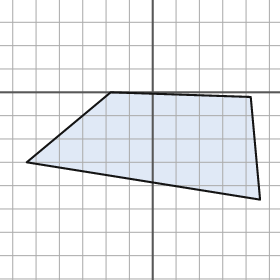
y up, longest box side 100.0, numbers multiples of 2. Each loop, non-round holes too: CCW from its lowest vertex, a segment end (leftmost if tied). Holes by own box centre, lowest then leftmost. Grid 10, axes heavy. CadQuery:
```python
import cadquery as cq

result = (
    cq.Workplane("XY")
    .moveTo(46.0, -46.0)
    .lineTo(42.0, -2.0)
    .lineTo(-18.0, 0.0)
    .lineTo(-54.0, -30.0)
    .close()
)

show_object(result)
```